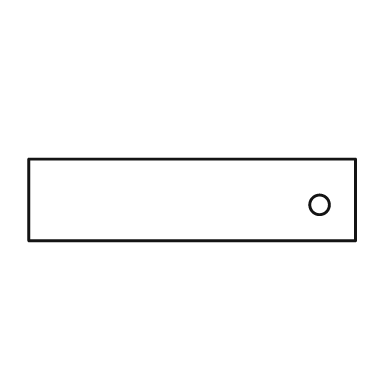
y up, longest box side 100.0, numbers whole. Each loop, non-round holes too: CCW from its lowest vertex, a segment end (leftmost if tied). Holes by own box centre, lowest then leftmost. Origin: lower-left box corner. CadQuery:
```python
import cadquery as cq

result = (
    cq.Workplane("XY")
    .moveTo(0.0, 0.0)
    .lineTo(100.0, 0.0)
    .lineTo(100.0, 25.0)
    .lineTo(0.0, 25.0)
    .close()
    .moveTo(89.0, 11.0)
    .circle(3.0)
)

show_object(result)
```